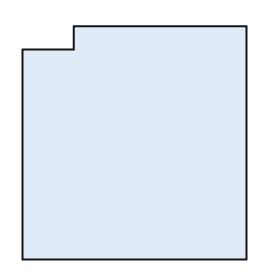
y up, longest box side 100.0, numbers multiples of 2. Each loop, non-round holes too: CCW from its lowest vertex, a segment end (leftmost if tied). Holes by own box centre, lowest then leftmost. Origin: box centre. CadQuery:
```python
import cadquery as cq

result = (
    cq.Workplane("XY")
    .moveTo(-48.0, -50.0)
    .lineTo(48.0, -50.0)
    .lineTo(48.0, 50.0)
    .lineTo(-26.0, 50.0)
    .lineTo(-26.0, 40.0)
    .lineTo(-48.0, 40.0)
    .close()
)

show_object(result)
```